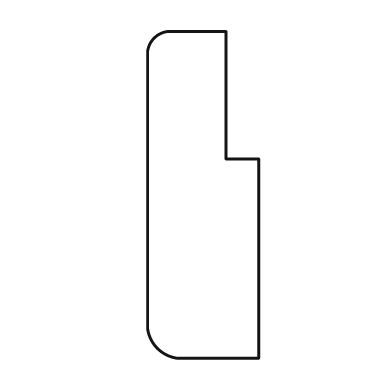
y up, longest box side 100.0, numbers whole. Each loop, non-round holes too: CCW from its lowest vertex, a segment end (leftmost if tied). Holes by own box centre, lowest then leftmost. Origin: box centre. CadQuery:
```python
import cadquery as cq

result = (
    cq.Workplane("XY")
    .moveTo(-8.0, -50.0)
    .lineTo(17.0, -50.0)
    .lineTo(17.0, 11.0)
    .lineTo(7.0, 11.0)
    .lineTo(7.0, 50.0)
    .lineTo(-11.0, 50.0)
    .threePointArc((-15.0, 48.0), (-17.0, 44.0))
    .lineTo(-17.0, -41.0)
    .threePointArc((-14.0, -47.0), (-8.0, -50.0))
    .close()
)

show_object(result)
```